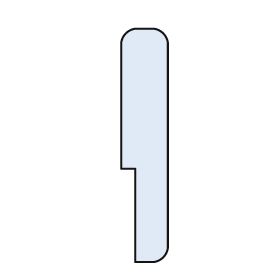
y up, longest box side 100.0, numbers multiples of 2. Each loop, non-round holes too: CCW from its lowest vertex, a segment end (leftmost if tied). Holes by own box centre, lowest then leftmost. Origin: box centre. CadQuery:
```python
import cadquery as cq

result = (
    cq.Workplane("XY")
    .moveTo(-4.0, -50.0)
    .lineTo(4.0, -50.0)
    .threePointArc((8.0, -48.0), (10.0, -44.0))
    .lineTo(10.0, 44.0)
    .threePointArc((8.0, 48.0), (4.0, 50.0))
    .lineTo(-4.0, 50.0)
    .threePointArc((-8.0, 48.0), (-10.0, 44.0))
    .lineTo(-10.0, -10.0)
    .lineTo(-4.0, -10.0)
    .close()
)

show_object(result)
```